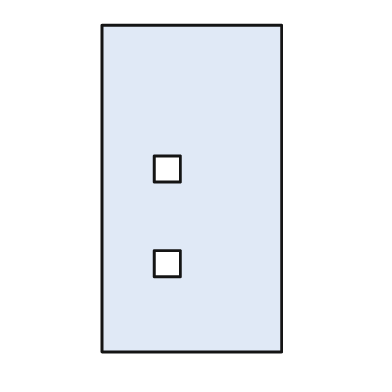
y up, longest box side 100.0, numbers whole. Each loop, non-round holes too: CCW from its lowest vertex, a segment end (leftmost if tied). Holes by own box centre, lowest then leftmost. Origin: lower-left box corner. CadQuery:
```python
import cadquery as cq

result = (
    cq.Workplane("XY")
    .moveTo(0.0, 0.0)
    .lineTo(55.0, 0.0)
    .lineTo(55.0, 100.0)
    .lineTo(0.0, 100.0)
    .close()
    .moveTo(16.0, 23.0)
    .lineTo(24.0, 23.0)
    .lineTo(24.0, 31.0)
    .lineTo(16.0, 31.0)
    .close()
    .moveTo(16.0, 52.0)
    .lineTo(24.0, 52.0)
    .lineTo(24.0, 60.0)
    .lineTo(16.0, 60.0)
    .close()
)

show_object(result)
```